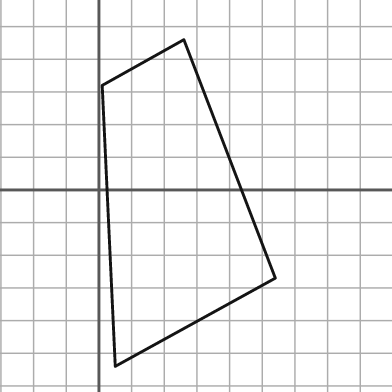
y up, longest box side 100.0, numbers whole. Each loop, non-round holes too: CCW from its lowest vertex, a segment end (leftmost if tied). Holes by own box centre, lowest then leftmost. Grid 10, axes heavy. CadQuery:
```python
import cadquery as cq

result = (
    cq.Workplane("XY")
    .moveTo(5.0, -54.0)
    .lineTo(54.0, -27.0)
    .lineTo(26.0, 46.0)
    .lineTo(1.0, 32.0)
    .close()
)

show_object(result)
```